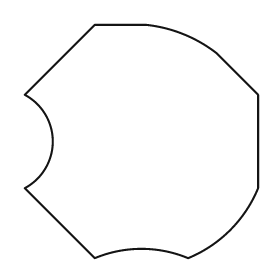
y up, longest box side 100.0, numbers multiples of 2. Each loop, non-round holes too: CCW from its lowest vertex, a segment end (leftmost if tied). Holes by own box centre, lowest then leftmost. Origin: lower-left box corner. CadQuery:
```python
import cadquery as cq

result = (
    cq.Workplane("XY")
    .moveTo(30.0, 0.0)
    .threePointArc((50.0, 4.0), (70.0, 0.0))
    .threePointArc((88.0, 12.0), (100.0, 30.0))
    .lineTo(100.0, 70.0)
    .lineTo(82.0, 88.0)
    .threePointArc((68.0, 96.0), (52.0, 100.0))
    .lineTo(30.0, 100.0)
    .lineTo(0.0, 70.0)
    .threePointArc((12.0, 50.0), (0.0, 30.0))
    .close()
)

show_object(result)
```